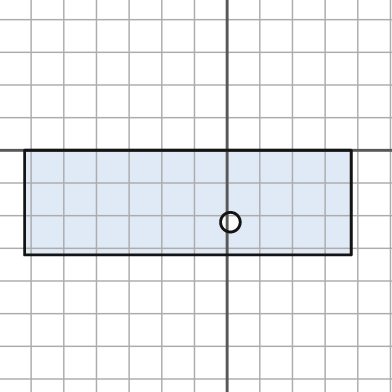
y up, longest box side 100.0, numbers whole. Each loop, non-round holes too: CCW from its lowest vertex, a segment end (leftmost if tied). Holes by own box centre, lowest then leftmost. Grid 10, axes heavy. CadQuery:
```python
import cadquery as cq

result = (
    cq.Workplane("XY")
    .moveTo(-62.0, -32.0)
    .lineTo(38.0, -32.0)
    .lineTo(38.0, 0.0)
    .lineTo(-62.0, 0.0)
    .close()
    .moveTo(1.0, -22.0)
    .circle(3.0)
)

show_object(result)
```